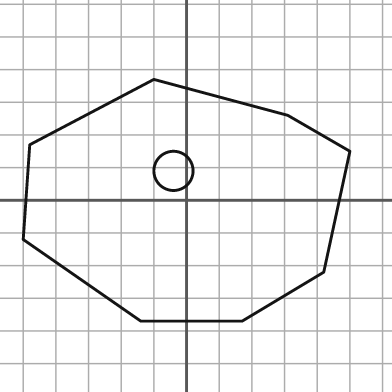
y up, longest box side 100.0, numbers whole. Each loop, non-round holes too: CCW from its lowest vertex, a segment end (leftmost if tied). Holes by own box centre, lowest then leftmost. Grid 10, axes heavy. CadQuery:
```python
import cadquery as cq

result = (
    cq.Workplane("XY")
    .moveTo(-14.0, -37.0)
    .lineTo(17.0, -37.0)
    .lineTo(42.0, -22.0)
    .lineTo(50.0, 15.0)
    .lineTo(31.0, 26.0)
    .lineTo(-10.0, 37.0)
    .lineTo(-48.0, 17.0)
    .lineTo(-50.0, -12.0)
    .close()
    .moveTo(-4.0, 9.0)
    .circle(6.0)
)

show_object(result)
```